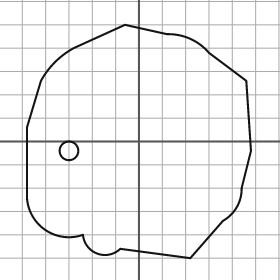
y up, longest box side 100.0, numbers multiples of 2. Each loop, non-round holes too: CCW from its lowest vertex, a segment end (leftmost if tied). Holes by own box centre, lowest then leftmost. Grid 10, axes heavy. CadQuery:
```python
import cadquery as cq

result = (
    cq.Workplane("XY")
    .moveTo(22.0, -50.0)
    .lineTo(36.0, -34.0)
    .threePointArc((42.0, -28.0), (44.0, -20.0))
    .lineTo(48.0, -4.0)
    .lineTo(46.0, 26.0)
    .lineTo(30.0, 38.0)
    .threePointArc((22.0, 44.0), (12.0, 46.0))
    .lineTo(-6.0, 50.0)
    .lineTo(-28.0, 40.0)
    .threePointArc((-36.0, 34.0), (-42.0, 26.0))
    .lineTo(-48.0, 6.0)
    .lineTo(-48.0, -24.0)
    .threePointArc((-40.0, -38.0), (-24.0, -40.0))
    .threePointArc((-18.0, -48.0), (-8.0, -46.0))
    .close()
    .moveTo(-30.0, -4.0)
    .circle(4.0)
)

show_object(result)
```